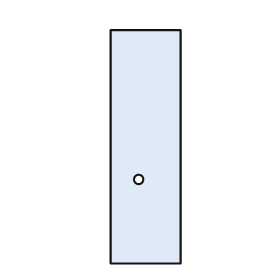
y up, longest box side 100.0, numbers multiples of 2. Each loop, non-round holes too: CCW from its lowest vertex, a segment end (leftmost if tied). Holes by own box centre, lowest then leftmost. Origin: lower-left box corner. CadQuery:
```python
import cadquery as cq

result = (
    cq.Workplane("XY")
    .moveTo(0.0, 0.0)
    .lineTo(30.0, 0.0)
    .lineTo(30.0, 100.0)
    .lineTo(0.0, 100.0)
    .close()
    .moveTo(12.0, 36.0)
    .circle(2.0)
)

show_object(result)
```